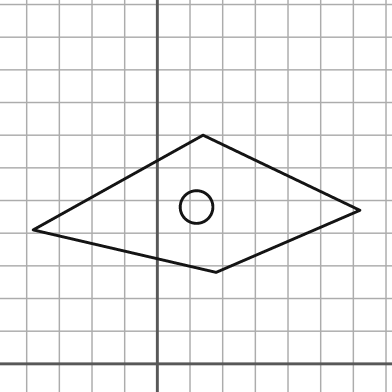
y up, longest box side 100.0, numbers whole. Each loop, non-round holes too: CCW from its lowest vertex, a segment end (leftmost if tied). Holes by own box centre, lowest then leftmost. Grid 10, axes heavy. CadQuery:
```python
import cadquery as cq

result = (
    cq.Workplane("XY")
    .moveTo(18.0, 28.0)
    .lineTo(62.0, 47.0)
    .lineTo(14.0, 70.0)
    .lineTo(-38.0, 41.0)
    .close()
    .moveTo(12.0, 48.0)
    .circle(5.0)
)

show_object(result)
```